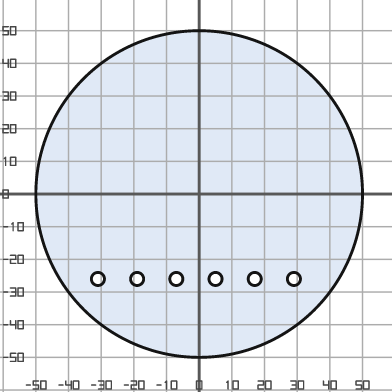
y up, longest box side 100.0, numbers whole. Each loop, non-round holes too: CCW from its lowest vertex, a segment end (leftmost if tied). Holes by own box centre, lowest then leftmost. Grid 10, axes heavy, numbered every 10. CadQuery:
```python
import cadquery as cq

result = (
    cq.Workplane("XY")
    .moveTo(0.0, 0.0)
    .circle(50.0)
    .moveTo(-31.0, -26.0)
    .circle(2.0)
    .moveTo(-19.0, -26.0)
    .circle(2.0)
    .moveTo(-7.0, -26.0)
    .circle(2.0)
    .moveTo(5.0, -26.0)
    .circle(2.0)
    .moveTo(17.0, -26.0)
    .circle(2.0)
    .moveTo(29.0, -26.0)
    .circle(2.0)
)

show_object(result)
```